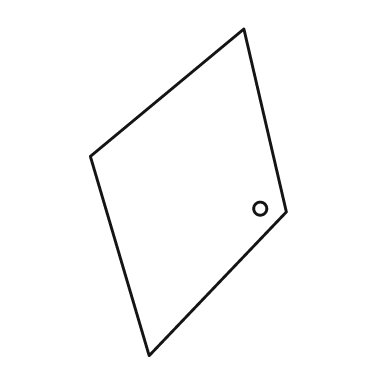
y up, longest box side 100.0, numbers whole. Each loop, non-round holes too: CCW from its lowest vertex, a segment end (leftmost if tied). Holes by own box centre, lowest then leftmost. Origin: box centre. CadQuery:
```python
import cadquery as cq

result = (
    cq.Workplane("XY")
    .moveTo(-12.0, -50.0)
    .lineTo(30.0, -6.0)
    .lineTo(17.0, 50.0)
    .lineTo(-30.0, 11.0)
    .close()
    .moveTo(22.0, -5.0)
    .circle(2.0)
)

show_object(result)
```